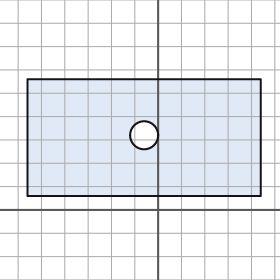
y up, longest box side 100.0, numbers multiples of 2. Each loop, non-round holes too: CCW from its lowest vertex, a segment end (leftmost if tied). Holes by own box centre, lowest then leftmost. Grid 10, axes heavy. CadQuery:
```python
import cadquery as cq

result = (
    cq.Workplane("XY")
    .moveTo(-56.0, 6.0)
    .lineTo(44.0, 6.0)
    .lineTo(44.0, 56.0)
    .lineTo(-56.0, 56.0)
    .close()
    .moveTo(-6.0, 32.0)
    .circle(6.0)
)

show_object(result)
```